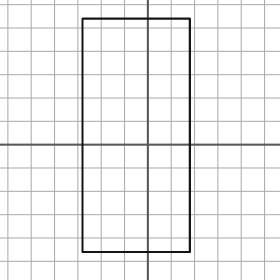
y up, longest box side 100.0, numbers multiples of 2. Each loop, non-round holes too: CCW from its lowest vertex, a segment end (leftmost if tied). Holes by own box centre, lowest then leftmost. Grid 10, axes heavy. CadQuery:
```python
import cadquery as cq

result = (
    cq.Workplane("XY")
    .moveTo(-28.0, -46.0)
    .lineTo(18.0, -46.0)
    .lineTo(18.0, 54.0)
    .lineTo(-28.0, 54.0)
    .close()
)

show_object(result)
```